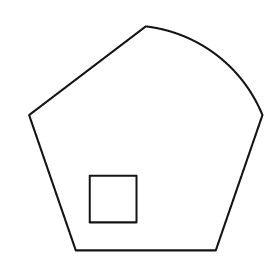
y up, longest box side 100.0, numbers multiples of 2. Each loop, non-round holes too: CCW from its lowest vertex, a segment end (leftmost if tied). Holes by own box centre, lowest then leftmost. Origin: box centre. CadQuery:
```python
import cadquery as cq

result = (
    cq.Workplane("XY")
    .moveTo(-30.0, -48.0)
    .lineTo(30.0, -48.0)
    .lineTo(50.0, 10.0)
    .threePointArc((30.0, 36.0), (0.0, 48.0))
    .lineTo(-50.0, 10.0)
    .close()
    .moveTo(-24.0, -36.0)
    .lineTo(-4.0, -36.0)
    .lineTo(-4.0, -16.0)
    .lineTo(-24.0, -16.0)
    .close()
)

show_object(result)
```